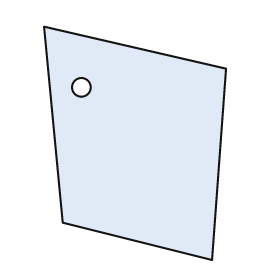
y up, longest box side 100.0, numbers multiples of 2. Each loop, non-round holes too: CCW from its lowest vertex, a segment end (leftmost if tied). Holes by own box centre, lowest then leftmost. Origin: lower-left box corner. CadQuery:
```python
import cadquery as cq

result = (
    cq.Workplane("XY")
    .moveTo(72.0, 0.0)
    .lineTo(78.0, 82.0)
    .lineTo(0.0, 100.0)
    .lineTo(8.0, 16.0)
    .close()
    .moveTo(16.0, 74.0)
    .circle(4.0)
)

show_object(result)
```